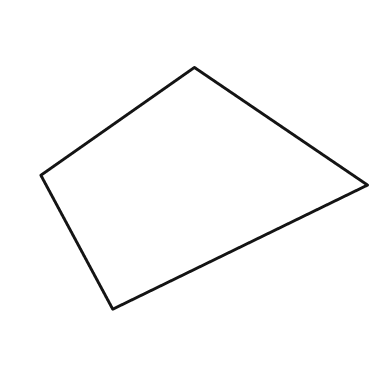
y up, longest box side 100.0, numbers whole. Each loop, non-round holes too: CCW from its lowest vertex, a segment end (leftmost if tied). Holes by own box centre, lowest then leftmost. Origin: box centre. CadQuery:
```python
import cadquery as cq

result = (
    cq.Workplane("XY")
    .moveTo(-28.0, -37.0)
    .lineTo(50.0, 1.0)
    .lineTo(-3.0, 37.0)
    .lineTo(-50.0, 4.0)
    .close()
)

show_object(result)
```